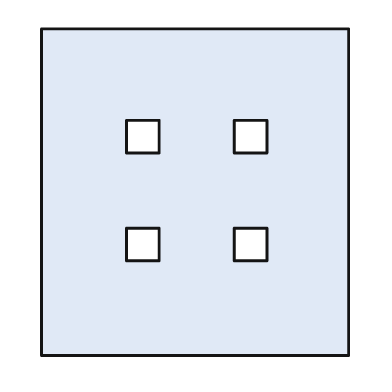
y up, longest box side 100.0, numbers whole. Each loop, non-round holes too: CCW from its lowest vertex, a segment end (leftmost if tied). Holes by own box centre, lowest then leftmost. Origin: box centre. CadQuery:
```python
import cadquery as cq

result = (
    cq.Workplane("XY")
    .moveTo(-47.0, -50.0)
    .lineTo(47.0, -50.0)
    .lineTo(47.0, 50.0)
    .lineTo(-47.0, 50.0)
    .close()
    .moveTo(-21.0, -21.0)
    .lineTo(-11.0, -21.0)
    .lineTo(-11.0, -11.0)
    .lineTo(-21.0, -11.0)
    .close()
    .moveTo(12.0, -21.0)
    .lineTo(22.0, -21.0)
    .lineTo(22.0, -11.0)
    .lineTo(12.0, -11.0)
    .close()
    .moveTo(-21.0, 12.0)
    .lineTo(-11.0, 12.0)
    .lineTo(-11.0, 22.0)
    .lineTo(-21.0, 22.0)
    .close()
    .moveTo(12.0, 12.0)
    .lineTo(22.0, 12.0)
    .lineTo(22.0, 22.0)
    .lineTo(12.0, 22.0)
    .close()
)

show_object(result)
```